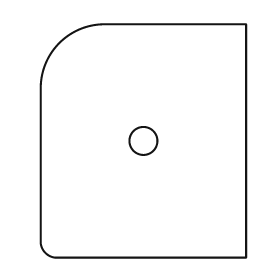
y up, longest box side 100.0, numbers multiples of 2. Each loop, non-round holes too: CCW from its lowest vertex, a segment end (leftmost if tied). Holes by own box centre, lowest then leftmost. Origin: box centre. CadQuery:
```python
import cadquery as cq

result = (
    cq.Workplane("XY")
    .moveTo(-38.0, -50.0)
    .lineTo(44.0, -50.0)
    .lineTo(44.0, 50.0)
    .lineTo(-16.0, 50.0)
    .threePointArc((-36.0, 42.0), (-44.0, 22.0))
    .lineTo(-44.0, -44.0)
    .threePointArc((-42.0, -48.0), (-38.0, -50.0))
    .close()
    .moveTo(0.0, 0.0)
    .circle(6.0)
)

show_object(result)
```